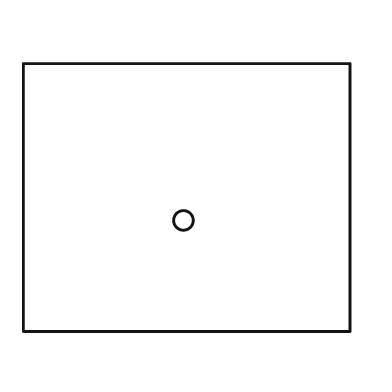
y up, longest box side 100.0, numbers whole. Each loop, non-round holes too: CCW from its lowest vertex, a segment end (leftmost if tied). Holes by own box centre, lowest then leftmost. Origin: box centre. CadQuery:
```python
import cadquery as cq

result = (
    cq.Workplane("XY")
    .moveTo(-50.0, -41.0)
    .lineTo(50.0, -41.0)
    .lineTo(50.0, 41.0)
    .lineTo(-50.0, 41.0)
    .close()
    .moveTo(-1.0, -7.0)
    .circle(3.0)
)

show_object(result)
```